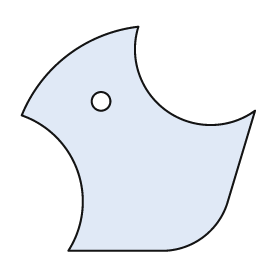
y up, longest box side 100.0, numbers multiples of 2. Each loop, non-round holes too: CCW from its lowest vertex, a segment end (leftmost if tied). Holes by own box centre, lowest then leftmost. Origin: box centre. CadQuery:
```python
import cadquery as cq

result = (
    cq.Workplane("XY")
    .moveTo(-30.0, -48.0)
    .lineTo(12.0, -48.0)
    .threePointArc((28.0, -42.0), (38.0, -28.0))
    .lineTo(50.0, 12.0)
    .threePointArc((12.0, 12.0), (0.0, 48.0))
    .threePointArc((-30.0, 36.0), (-50.0, 10.0))
    .threePointArc((-26.0, -14.0), (-30.0, -48.0))
    .close()
    .moveTo(-16.0, 16.0)
    .circle(4.0)
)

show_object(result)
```